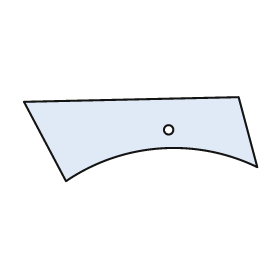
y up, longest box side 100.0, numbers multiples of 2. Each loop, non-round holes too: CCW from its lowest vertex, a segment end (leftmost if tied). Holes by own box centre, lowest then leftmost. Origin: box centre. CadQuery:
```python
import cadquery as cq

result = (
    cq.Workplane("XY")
    .moveTo(-32.0, -18.0)
    .threePointArc((8.0, -4.0), (50.0, -12.0))
    .lineTo(42.0, 18.0)
    .lineTo(-50.0, 16.0)
    .close()
    .moveTo(12.0, 4.0)
    .circle(2.0)
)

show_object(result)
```